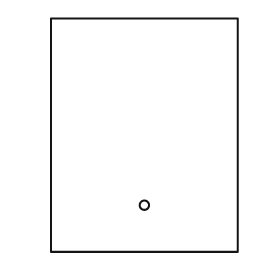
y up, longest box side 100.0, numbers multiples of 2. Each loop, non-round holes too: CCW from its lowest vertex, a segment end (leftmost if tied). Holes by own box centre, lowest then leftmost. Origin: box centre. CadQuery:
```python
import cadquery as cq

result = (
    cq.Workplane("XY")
    .moveTo(-40.0, -50.0)
    .lineTo(40.0, -50.0)
    .lineTo(40.0, 50.0)
    .lineTo(-40.0, 50.0)
    .close()
    .moveTo(0.0, -30.0)
    .circle(2.0)
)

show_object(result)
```